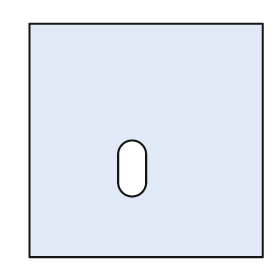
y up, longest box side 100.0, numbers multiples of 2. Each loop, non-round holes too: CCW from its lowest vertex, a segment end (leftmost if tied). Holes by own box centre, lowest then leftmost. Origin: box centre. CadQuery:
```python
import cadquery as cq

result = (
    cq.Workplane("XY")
    .moveTo(-50.0, -50.0)
    .lineTo(50.0, -50.0)
    .lineTo(50.0, 50.0)
    .lineTo(-50.0, 50.0)
    .close()
    .moveTo(-12.0, -18.0)
    .threePointArc((-6.0, -24.0), (0.0, -18.0))
    .lineTo(0.0, -6.0)
    .threePointArc((-6.0, 0.0), (-12.0, -6.0))
    .close()
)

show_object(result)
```